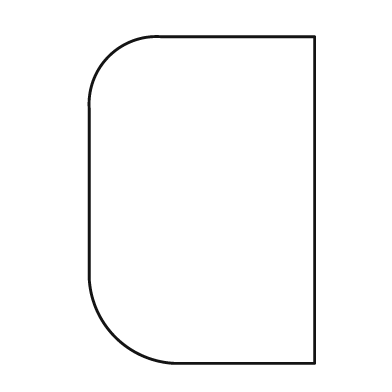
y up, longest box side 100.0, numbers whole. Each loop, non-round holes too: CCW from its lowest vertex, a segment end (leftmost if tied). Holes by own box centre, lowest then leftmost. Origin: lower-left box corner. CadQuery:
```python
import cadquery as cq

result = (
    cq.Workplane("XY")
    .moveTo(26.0, 0.0)
    .lineTo(69.0, 0.0)
    .lineTo(69.0, 100.0)
    .lineTo(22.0, 100.0)
    .threePointArc((6.0, 94.0), (0.0, 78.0))
    .lineTo(0.0, 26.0)
    .threePointArc((8.0, 8.0), (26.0, 0.0))
    .close()
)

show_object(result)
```